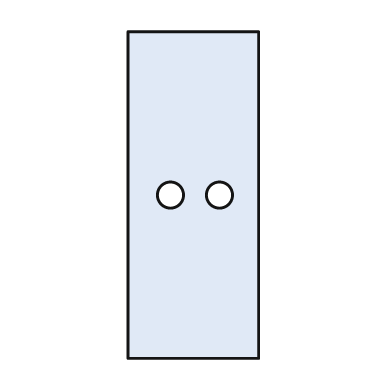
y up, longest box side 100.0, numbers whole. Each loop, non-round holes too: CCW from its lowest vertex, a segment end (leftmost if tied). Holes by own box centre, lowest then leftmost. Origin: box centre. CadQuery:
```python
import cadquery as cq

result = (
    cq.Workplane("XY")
    .moveTo(-20.0, -50.0)
    .lineTo(20.0, -50.0)
    .lineTo(20.0, 50.0)
    .lineTo(-20.0, 50.0)
    .close()
    .moveTo(-7.0, 0.0)
    .circle(4.0)
    .moveTo(8.0, 0.0)
    .circle(4.0)
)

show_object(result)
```